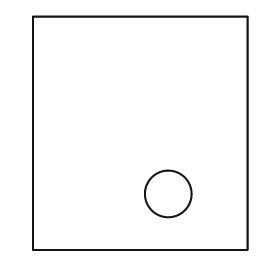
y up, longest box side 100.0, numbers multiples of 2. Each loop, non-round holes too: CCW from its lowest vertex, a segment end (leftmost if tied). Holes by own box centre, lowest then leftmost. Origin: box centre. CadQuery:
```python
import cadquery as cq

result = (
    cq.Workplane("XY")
    .moveTo(-46.0, -50.0)
    .lineTo(46.0, -50.0)
    .lineTo(46.0, 50.0)
    .lineTo(-46.0, 50.0)
    .close()
    .moveTo(12.0, -26.0)
    .circle(10.0)
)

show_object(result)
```